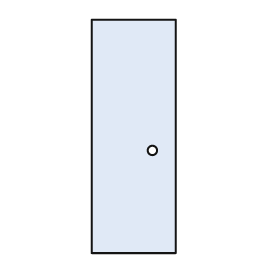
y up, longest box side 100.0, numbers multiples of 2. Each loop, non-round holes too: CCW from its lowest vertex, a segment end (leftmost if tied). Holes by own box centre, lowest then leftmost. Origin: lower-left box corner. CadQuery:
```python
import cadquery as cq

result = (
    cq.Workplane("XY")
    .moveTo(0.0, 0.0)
    .lineTo(36.0, 0.0)
    .lineTo(36.0, 100.0)
    .lineTo(0.0, 100.0)
    .close()
    .moveTo(26.0, 44.0)
    .circle(2.0)
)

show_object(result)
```